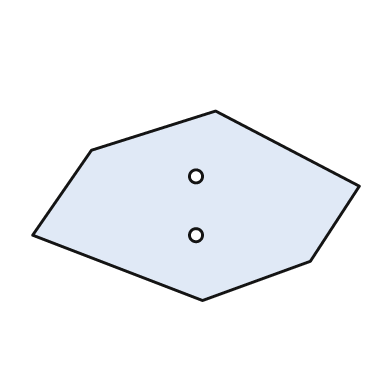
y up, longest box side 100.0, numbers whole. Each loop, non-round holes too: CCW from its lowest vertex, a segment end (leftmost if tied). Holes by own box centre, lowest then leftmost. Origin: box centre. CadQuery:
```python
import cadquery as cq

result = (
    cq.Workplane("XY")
    .moveTo(2.0, -29.0)
    .lineTo(35.0, -17.0)
    .lineTo(50.0, 6.0)
    .lineTo(6.0, 29.0)
    .lineTo(-32.0, 17.0)
    .lineTo(-50.0, -9.0)
    .close()
    .moveTo(0.0, -9.0)
    .circle(2.0)
    .moveTo(0.0, 9.0)
    .circle(2.0)
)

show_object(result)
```